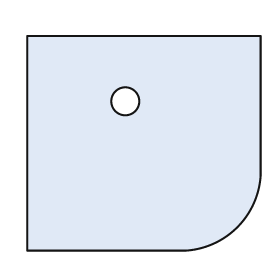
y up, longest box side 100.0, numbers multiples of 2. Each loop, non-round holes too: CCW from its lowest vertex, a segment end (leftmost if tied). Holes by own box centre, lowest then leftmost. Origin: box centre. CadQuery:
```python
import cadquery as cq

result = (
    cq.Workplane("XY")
    .moveTo(-50.0, -46.0)
    .lineTo(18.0, -46.0)
    .threePointArc((40.0, -36.0), (50.0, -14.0))
    .lineTo(50.0, 46.0)
    .lineTo(-50.0, 46.0)
    .close()
    .moveTo(-8.0, 18.0)
    .circle(6.0)
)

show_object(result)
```